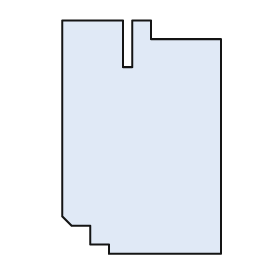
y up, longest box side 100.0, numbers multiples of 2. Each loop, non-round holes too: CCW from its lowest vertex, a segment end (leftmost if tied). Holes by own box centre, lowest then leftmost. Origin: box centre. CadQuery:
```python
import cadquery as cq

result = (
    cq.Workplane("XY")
    .moveTo(-14.0, -50.0)
    .lineTo(34.0, -50.0)
    .lineTo(34.0, 42.0)
    .lineTo(4.0, 42.0)
    .lineTo(4.0, 50.0)
    .lineTo(-4.0, 50.0)
    .lineTo(-4.0, 30.0)
    .lineTo(-8.0, 30.0)
    .lineTo(-8.0, 50.0)
    .lineTo(-34.0, 50.0)
    .lineTo(-34.0, -34.0)
    .lineTo(-30.0, -38.0)
    .lineTo(-22.0, -38.0)
    .lineTo(-22.0, -46.0)
    .lineTo(-14.0, -46.0)
    .close()
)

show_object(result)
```